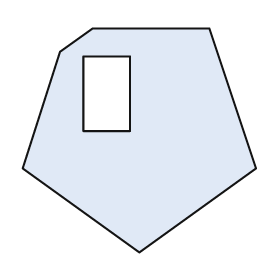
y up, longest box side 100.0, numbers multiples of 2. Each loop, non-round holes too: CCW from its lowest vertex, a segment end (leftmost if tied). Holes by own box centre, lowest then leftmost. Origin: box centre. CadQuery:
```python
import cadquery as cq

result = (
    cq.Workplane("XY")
    .moveTo(0.0, -48.0)
    .lineTo(50.0, -12.0)
    .lineTo(30.0, 48.0)
    .lineTo(-20.0, 48.0)
    .lineTo(-34.0, 38.0)
    .lineTo(-50.0, -12.0)
    .close()
    .moveTo(-24.0, 4.0)
    .lineTo(-4.0, 4.0)
    .lineTo(-4.0, 36.0)
    .lineTo(-24.0, 36.0)
    .close()
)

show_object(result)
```